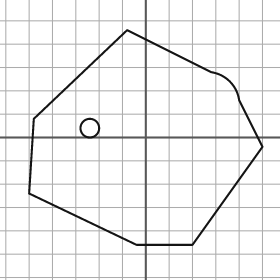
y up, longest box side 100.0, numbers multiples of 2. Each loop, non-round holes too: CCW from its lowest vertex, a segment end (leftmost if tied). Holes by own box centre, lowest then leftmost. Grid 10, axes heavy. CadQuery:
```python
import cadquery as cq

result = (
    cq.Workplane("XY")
    .moveTo(-4.0, -46.0)
    .lineTo(20.0, -46.0)
    .lineTo(50.0, -4.0)
    .lineTo(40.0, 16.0)
    .threePointArc((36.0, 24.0), (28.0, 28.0))
    .lineTo(-8.0, 46.0)
    .lineTo(-48.0, 8.0)
    .lineTo(-50.0, -24.0)
    .close()
    .moveTo(-24.0, 4.0)
    .circle(4.0)
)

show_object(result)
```